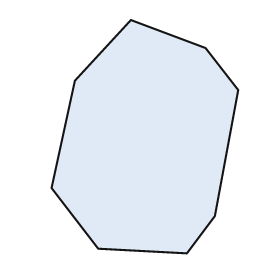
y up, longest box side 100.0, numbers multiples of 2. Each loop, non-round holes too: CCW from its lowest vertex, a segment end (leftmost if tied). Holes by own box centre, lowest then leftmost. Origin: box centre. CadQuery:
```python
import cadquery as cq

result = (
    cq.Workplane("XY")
    .moveTo(18.0, -50.0)
    .lineTo(30.0, -34.0)
    .lineTo(40.0, 20.0)
    .lineTo(26.0, 38.0)
    .lineTo(-6.0, 50.0)
    .lineTo(-30.0, 24.0)
    .lineTo(-40.0, -22.0)
    .lineTo(-20.0, -48.0)
    .close()
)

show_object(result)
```